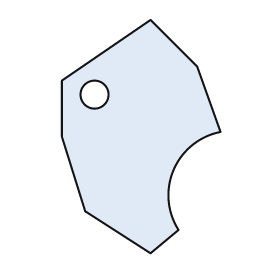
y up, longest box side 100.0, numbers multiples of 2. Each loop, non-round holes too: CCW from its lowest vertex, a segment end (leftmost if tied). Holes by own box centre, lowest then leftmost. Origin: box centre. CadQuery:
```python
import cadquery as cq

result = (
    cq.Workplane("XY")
    .moveTo(4.0, -50.0)
    .lineTo(16.0, -40.0)
    .threePointArc((14.0, -14.0), (34.0, 2.0))
    .lineTo(24.0, 30.0)
    .lineTo(4.0, 50.0)
    .lineTo(-34.0, 24.0)
    .lineTo(-34.0, 0.0)
    .lineTo(-24.0, -32.0)
    .close()
    .moveTo(-20.0, 18.0)
    .circle(6.0)
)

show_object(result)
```